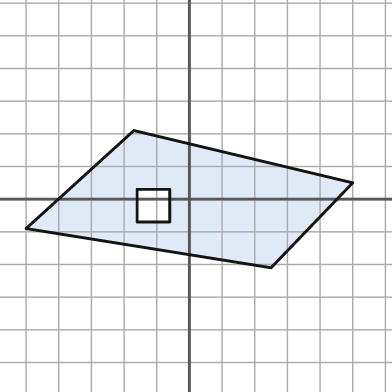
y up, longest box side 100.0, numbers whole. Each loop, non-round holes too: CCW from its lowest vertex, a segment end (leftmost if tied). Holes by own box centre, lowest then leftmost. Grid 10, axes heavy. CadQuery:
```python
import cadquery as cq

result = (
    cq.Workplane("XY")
    .moveTo(25.0, -21.0)
    .lineTo(50.0, 5.0)
    .lineTo(-17.0, 21.0)
    .lineTo(-50.0, -9.0)
    .close()
    .moveTo(-16.0, -7.0)
    .lineTo(-6.0, -7.0)
    .lineTo(-6.0, 3.0)
    .lineTo(-16.0, 3.0)
    .close()
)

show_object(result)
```